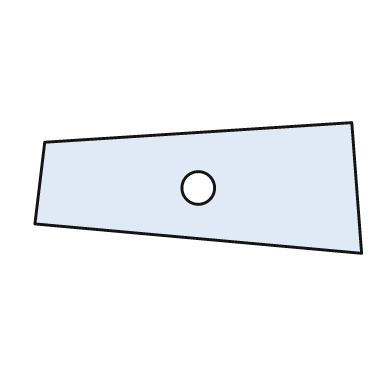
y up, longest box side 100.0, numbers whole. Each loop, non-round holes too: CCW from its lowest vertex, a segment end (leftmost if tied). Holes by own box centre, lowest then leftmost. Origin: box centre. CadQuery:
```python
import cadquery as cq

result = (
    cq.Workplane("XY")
    .moveTo(50.0, -20.0)
    .lineTo(47.0, 20.0)
    .lineTo(-47.0, 14.0)
    .lineTo(-50.0, -11.0)
    .close()
    .moveTo(0.0, 0.0)
    .circle(5.0)
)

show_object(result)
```